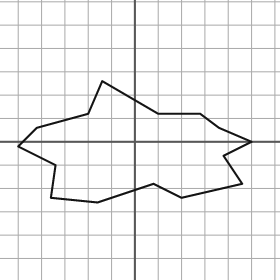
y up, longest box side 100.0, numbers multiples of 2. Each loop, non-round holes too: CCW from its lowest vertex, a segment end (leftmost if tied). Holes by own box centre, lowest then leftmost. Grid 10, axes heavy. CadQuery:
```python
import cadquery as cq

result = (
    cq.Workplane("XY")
    .moveTo(-16.0, -26.0)
    .lineTo(8.0, -18.0)
    .lineTo(20.0, -24.0)
    .lineTo(46.0, -18.0)
    .lineTo(38.0, -6.0)
    .lineTo(50.0, 0.0)
    .lineTo(36.0, 6.0)
    .lineTo(28.0, 12.0)
    .lineTo(10.0, 12.0)
    .lineTo(-14.0, 26.0)
    .lineTo(-20.0, 12.0)
    .lineTo(-42.0, 6.0)
    .lineTo(-50.0, -2.0)
    .lineTo(-34.0, -10.0)
    .lineTo(-36.0, -24.0)
    .close()
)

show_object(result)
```